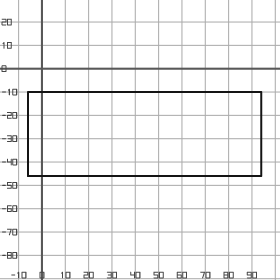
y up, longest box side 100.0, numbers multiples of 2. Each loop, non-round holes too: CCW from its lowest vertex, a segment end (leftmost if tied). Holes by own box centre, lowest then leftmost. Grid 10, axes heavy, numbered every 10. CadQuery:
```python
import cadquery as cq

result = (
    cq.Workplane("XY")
    .moveTo(-6.0, -46.0)
    .lineTo(94.0, -46.0)
    .lineTo(94.0, -10.0)
    .lineTo(-6.0, -10.0)
    .close()
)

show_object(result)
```